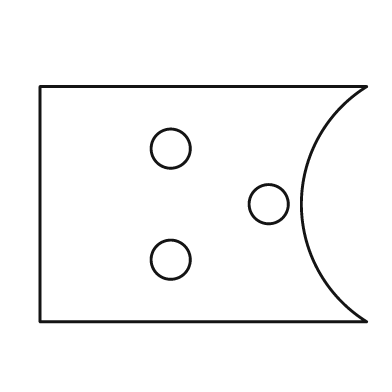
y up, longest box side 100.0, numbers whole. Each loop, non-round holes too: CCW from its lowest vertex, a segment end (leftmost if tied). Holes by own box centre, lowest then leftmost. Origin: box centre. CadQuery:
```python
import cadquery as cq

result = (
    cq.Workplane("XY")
    .moveTo(-50.0, -36.0)
    .lineTo(50.0, -36.0)
    .threePointArc((30.0, 0.0), (50.0, 36.0))
    .lineTo(-50.0, 36.0)
    .close()
    .moveTo(-10.0, -17.0)
    .circle(6.0)
    .moveTo(20.0, 0.0)
    .circle(6.0)
    .moveTo(-10.0, 17.0)
    .circle(6.0)
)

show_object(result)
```